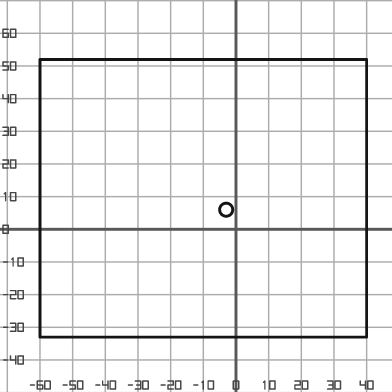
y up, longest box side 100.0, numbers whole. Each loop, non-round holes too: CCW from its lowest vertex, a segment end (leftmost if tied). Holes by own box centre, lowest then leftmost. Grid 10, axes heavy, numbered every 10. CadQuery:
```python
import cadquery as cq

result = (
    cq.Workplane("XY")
    .moveTo(-60.0, -33.0)
    .lineTo(40.0, -33.0)
    .lineTo(40.0, 52.0)
    .lineTo(-60.0, 52.0)
    .close()
    .moveTo(-3.0, 6.0)
    .circle(2.0)
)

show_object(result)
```